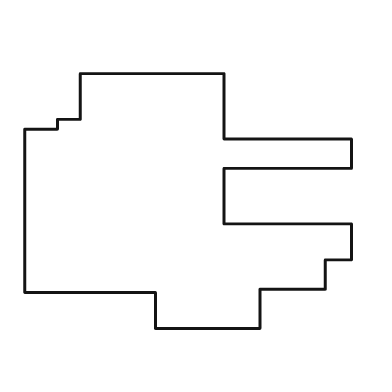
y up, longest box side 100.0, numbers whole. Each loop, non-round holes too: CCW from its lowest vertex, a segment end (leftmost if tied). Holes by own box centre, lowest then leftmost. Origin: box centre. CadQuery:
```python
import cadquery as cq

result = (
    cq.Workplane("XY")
    .moveTo(-10.0, -39.0)
    .lineTo(22.0, -39.0)
    .lineTo(22.0, -27.0)
    .lineTo(42.0, -27.0)
    .lineTo(42.0, -18.0)
    .lineTo(50.0, -18.0)
    .lineTo(50.0, -7.0)
    .lineTo(11.0, -7.0)
    .lineTo(11.0, 10.0)
    .lineTo(50.0, 10.0)
    .lineTo(50.0, 19.0)
    .lineTo(11.0, 19.0)
    .lineTo(11.0, 39.0)
    .lineTo(-33.0, 39.0)
    .lineTo(-33.0, 25.0)
    .lineTo(-40.0, 25.0)
    .lineTo(-40.0, 22.0)
    .lineTo(-50.0, 22.0)
    .lineTo(-50.0, -28.0)
    .lineTo(-10.0, -28.0)
    .close()
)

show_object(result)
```